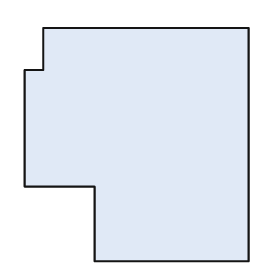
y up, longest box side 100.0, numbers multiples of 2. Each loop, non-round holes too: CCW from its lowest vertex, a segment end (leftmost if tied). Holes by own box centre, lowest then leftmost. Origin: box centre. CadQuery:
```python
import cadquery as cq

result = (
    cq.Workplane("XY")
    .moveTo(-18.0, -50.0)
    .lineTo(48.0, -50.0)
    .lineTo(48.0, 50.0)
    .lineTo(-40.0, 50.0)
    .lineTo(-40.0, 32.0)
    .lineTo(-48.0, 32.0)
    .lineTo(-48.0, -18.0)
    .lineTo(-18.0, -18.0)
    .close()
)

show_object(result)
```